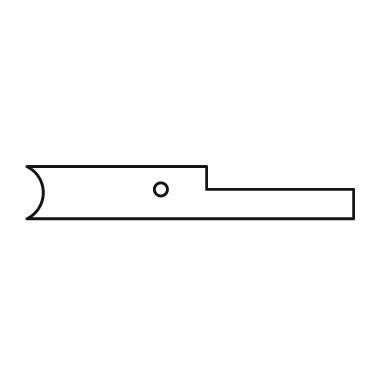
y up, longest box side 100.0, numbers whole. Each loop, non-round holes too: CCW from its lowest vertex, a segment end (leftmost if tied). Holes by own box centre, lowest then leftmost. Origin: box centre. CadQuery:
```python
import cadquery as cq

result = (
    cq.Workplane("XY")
    .moveTo(-50.0, -8.0)
    .lineTo(50.0, -8.0)
    .lineTo(50.0, 1.0)
    .lineTo(5.0, 1.0)
    .lineTo(5.0, 8.0)
    .lineTo(-50.0, 8.0)
    .threePointArc((-45.0, 0.0), (-50.0, -8.0))
    .close()
    .moveTo(-9.0, 1.0)
    .circle(2.0)
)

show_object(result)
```